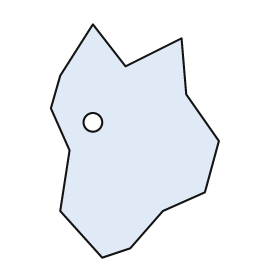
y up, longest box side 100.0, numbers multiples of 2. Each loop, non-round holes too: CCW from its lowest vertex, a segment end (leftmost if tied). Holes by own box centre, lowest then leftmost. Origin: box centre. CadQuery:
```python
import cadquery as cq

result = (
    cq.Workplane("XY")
    .moveTo(-14.0, -50.0)
    .lineTo(-2.0, -46.0)
    .lineTo(12.0, -30.0)
    .lineTo(30.0, -22.0)
    .lineTo(36.0, 0.0)
    .lineTo(22.0, 20.0)
    .lineTo(20.0, 44.0)
    .lineTo(-4.0, 32.0)
    .lineTo(-18.0, 50.0)
    .lineTo(-32.0, 28.0)
    .lineTo(-36.0, 14.0)
    .lineTo(-28.0, -4.0)
    .lineTo(-32.0, -30.0)
    .close()
    .moveTo(-18.0, 8.0)
    .circle(4.0)
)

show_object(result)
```